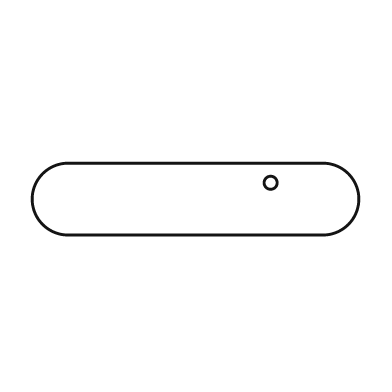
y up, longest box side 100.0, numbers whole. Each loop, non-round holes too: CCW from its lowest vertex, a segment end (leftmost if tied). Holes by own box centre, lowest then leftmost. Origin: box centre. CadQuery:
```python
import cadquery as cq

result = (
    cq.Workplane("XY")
    .moveTo(-39.0, -11.0)
    .lineTo(39.0, -11.0)
    .threePointArc((50.0, 0.0), (39.0, 11.0))
    .lineTo(-39.0, 11.0)
    .threePointArc((-50.0, 0.0), (-39.0, -11.0))
    .close()
    .moveTo(23.0, 5.0)
    .circle(2.0)
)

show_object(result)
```